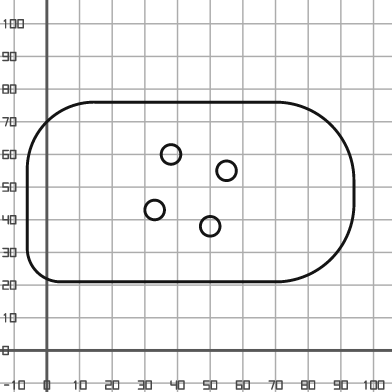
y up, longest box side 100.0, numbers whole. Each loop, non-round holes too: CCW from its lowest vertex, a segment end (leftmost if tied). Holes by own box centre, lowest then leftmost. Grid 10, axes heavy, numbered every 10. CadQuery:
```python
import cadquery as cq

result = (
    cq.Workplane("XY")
    .moveTo(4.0, 21.0)
    .lineTo(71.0, 21.0)
    .threePointArc((87.0, 28.0), (94.0, 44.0))
    .lineTo(94.0, 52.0)
    .threePointArc((87.0, 69.0), (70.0, 76.0))
    .lineTo(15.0, 76.0)
    .threePointArc((0.0, 70.0), (-6.0, 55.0))
    .lineTo(-6.0, 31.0)
    .threePointArc((-3.0, 24.0), (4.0, 21.0))
    .close()
    .moveTo(50.0, 38.0)
    .circle(3.0)
    .moveTo(33.0, 43.0)
    .circle(3.0)
    .moveTo(55.0, 55.0)
    .circle(3.0)
    .moveTo(38.0, 60.0)
    .circle(3.0)
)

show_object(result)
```